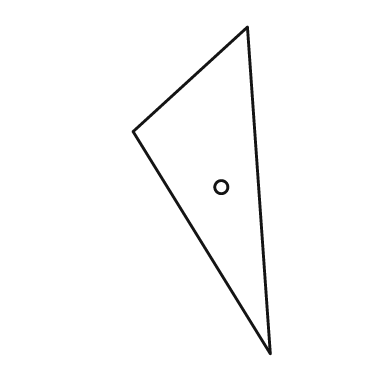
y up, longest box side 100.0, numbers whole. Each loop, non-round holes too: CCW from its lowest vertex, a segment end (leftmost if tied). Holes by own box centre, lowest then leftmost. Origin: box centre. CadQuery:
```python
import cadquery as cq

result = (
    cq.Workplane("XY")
    .moveTo(21.0, -50.0)
    .lineTo(14.0, 50.0)
    .lineTo(-21.0, 18.0)
    .close()
    .moveTo(6.0, 1.0)
    .circle(2.0)
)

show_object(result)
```